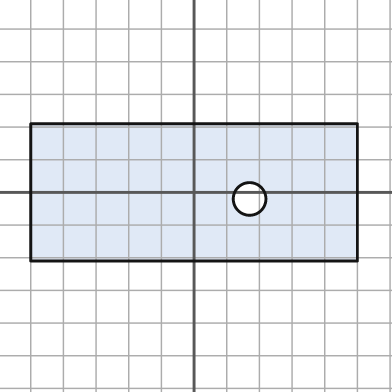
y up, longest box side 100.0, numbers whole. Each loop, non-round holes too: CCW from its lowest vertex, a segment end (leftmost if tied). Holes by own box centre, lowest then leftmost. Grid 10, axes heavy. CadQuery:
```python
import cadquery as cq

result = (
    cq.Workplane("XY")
    .moveTo(-50.0, -21.0)
    .lineTo(50.0, -21.0)
    .lineTo(50.0, 21.0)
    .lineTo(-50.0, 21.0)
    .close()
    .moveTo(17.0, -2.0)
    .circle(5.0)
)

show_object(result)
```